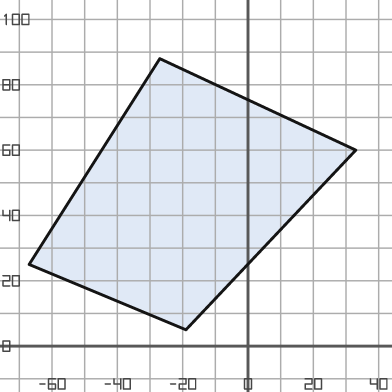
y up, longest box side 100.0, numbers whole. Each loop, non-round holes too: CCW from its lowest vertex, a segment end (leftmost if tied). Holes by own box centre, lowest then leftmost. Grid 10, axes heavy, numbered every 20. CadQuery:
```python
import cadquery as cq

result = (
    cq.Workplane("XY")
    .moveTo(-19.0, 5.0)
    .lineTo(33.0, 60.0)
    .lineTo(-27.0, 88.0)
    .lineTo(-67.0, 25.0)
    .close()
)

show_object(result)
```